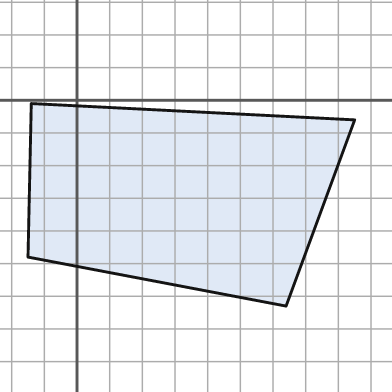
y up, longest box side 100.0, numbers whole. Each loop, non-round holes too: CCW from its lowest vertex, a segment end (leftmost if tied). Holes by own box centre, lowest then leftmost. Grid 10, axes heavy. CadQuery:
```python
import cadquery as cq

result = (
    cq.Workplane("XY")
    .moveTo(64.0, -63.0)
    .lineTo(85.0, -6.0)
    .lineTo(-14.0, -1.0)
    .lineTo(-15.0, -48.0)
    .close()
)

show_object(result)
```